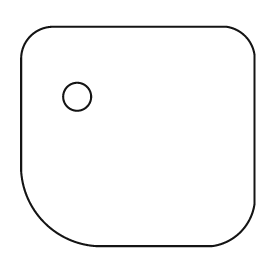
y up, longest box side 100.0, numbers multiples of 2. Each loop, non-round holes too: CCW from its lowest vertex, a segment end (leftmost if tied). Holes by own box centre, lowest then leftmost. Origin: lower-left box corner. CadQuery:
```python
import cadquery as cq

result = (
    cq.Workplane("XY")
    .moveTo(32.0, 0.0)
    .lineTo(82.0, 0.0)
    .threePointArc((94.0, 6.0), (100.0, 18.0))
    .lineTo(100.0, 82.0)
    .threePointArc((96.0, 90.0), (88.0, 94.0))
    .lineTo(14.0, 94.0)
    .threePointArc((4.0, 90.0), (0.0, 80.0))
    .lineTo(0.0, 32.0)
    .threePointArc((10.0, 10.0), (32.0, 0.0))
    .close()
    .moveTo(24.0, 64.0)
    .circle(6.0)
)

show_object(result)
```